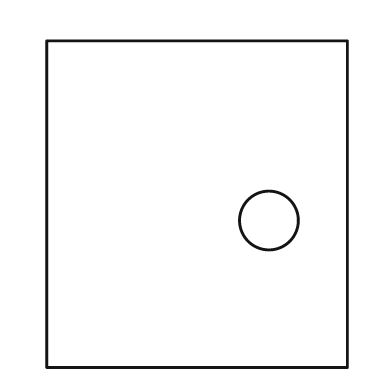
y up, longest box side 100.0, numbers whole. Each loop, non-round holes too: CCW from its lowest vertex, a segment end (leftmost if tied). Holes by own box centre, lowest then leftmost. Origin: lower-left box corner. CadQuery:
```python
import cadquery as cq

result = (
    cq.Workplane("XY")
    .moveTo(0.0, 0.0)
    .lineTo(92.0, 0.0)
    .lineTo(92.0, 100.0)
    .lineTo(0.0, 100.0)
    .close()
    .moveTo(68.0, 45.0)
    .circle(9.0)
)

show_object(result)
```